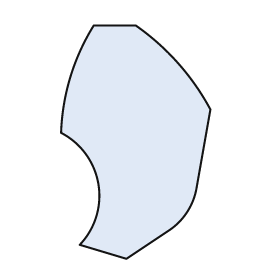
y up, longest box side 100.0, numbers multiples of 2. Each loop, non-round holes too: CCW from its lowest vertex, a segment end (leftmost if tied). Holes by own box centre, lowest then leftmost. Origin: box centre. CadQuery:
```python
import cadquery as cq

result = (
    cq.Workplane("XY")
    .moveTo(-4.0, -50.0)
    .lineTo(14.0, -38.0)
    .threePointArc((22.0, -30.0), (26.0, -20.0))
    .lineTo(32.0, 14.0)
    .threePointArc((18.0, 34.0), (0.0, 50.0))
    .lineTo(-18.0, 50.0)
    .threePointArc((-28.0, 28.0), (-32.0, 4.0))
    .threePointArc((-16.0, -18.0), (-24.0, -44.0))
    .close()
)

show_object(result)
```